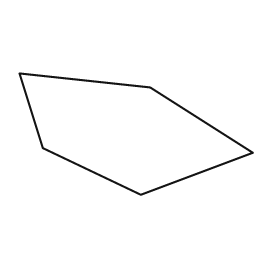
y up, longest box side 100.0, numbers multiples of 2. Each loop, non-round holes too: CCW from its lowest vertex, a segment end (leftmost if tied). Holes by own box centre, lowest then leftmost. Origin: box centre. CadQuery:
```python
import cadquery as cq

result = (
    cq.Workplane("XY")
    .moveTo(2.0, -26.0)
    .lineTo(50.0, -8.0)
    .lineTo(6.0, 20.0)
    .lineTo(-50.0, 26.0)
    .lineTo(-40.0, -6.0)
    .close()
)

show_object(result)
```